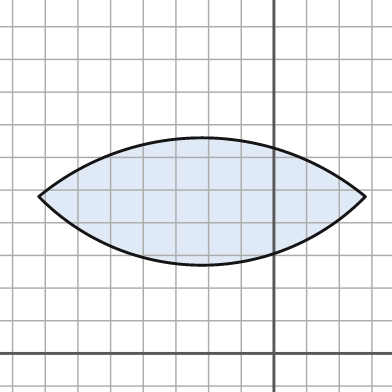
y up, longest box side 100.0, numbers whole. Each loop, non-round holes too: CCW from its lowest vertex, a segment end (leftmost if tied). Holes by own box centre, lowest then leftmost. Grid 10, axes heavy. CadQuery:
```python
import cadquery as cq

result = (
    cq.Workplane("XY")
    .moveTo(-72.0, 48.0)
    .threePointArc((-22.0, 27.0), (28.0, 48.0))
    .threePointArc((-22.0, 66.0), (-72.0, 48.0))
    .close()
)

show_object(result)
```